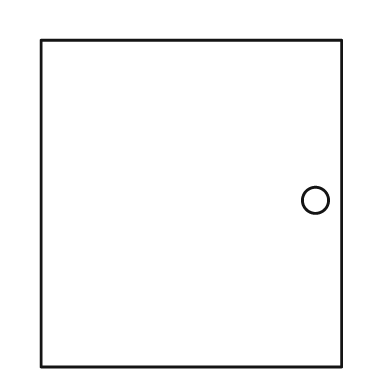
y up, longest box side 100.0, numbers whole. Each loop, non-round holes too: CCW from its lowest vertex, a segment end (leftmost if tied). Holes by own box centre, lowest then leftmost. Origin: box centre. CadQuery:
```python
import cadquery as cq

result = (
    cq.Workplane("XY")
    .moveTo(-46.0, -50.0)
    .lineTo(46.0, -50.0)
    .lineTo(46.0, 50.0)
    .lineTo(-46.0, 50.0)
    .close()
    .moveTo(38.0, 1.0)
    .circle(4.0)
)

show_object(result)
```